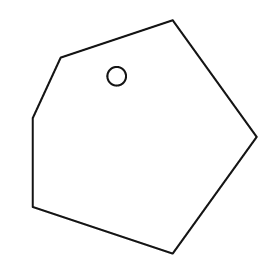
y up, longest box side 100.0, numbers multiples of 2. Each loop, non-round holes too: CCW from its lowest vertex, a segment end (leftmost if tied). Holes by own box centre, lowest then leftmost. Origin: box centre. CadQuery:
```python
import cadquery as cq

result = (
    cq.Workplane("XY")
    .moveTo(12.0, -50.0)
    .lineTo(48.0, 0.0)
    .lineTo(12.0, 50.0)
    .lineTo(-36.0, 34.0)
    .lineTo(-48.0, 8.0)
    .lineTo(-48.0, -30.0)
    .close()
    .moveTo(-12.0, 26.0)
    .circle(4.0)
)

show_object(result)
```